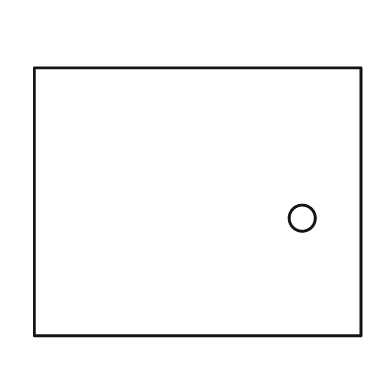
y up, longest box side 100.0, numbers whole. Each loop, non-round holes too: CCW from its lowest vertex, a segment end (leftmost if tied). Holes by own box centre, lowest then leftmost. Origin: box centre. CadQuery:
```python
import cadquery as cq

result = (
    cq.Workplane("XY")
    .moveTo(-50.0, -41.0)
    .lineTo(50.0, -41.0)
    .lineTo(50.0, 41.0)
    .lineTo(-50.0, 41.0)
    .close()
    .moveTo(32.0, -5.0)
    .circle(4.0)
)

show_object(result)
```